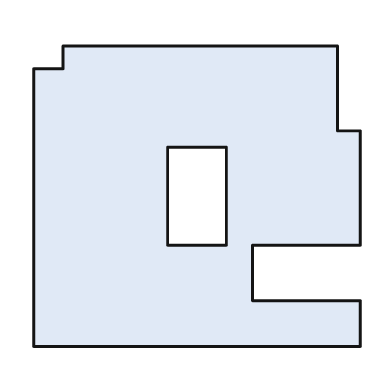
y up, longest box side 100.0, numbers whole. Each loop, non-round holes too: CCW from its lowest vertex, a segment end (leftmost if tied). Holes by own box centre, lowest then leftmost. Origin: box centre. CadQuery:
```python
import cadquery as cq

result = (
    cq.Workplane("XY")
    .moveTo(-50.0, -46.0)
    .lineTo(50.0, -46.0)
    .lineTo(50.0, -32.0)
    .lineTo(17.0, -32.0)
    .lineTo(17.0, -15.0)
    .lineTo(50.0, -15.0)
    .lineTo(50.0, 20.0)
    .lineTo(43.0, 20.0)
    .lineTo(43.0, 46.0)
    .lineTo(-41.0, 46.0)
    .lineTo(-41.0, 39.0)
    .lineTo(-50.0, 39.0)
    .close()
    .moveTo(-9.0, -15.0)
    .lineTo(9.0, -15.0)
    .lineTo(9.0, 15.0)
    .lineTo(-9.0, 15.0)
    .close()
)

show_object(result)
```